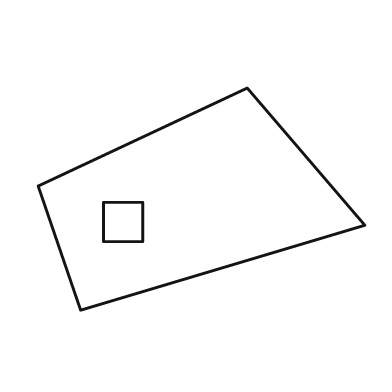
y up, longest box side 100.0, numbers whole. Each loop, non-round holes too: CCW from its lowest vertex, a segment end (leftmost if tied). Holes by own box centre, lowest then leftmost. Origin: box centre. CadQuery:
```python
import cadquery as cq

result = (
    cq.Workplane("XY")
    .moveTo(-37.0, -34.0)
    .lineTo(50.0, -8.0)
    .lineTo(14.0, 34.0)
    .lineTo(-50.0, 4.0)
    .close()
    .moveTo(-30.0, -13.0)
    .lineTo(-18.0, -13.0)
    .lineTo(-18.0, -1.0)
    .lineTo(-30.0, -1.0)
    .close()
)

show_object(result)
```